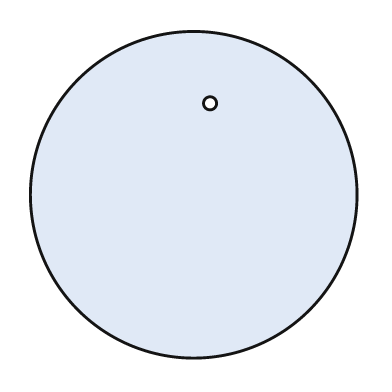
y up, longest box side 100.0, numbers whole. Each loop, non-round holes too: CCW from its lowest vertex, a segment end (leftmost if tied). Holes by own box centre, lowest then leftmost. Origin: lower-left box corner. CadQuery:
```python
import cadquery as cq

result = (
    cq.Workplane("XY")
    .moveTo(50.0, 50.0)
    .circle(50.0)
    .moveTo(55.0, 78.0)
    .circle(2.0)
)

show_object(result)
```